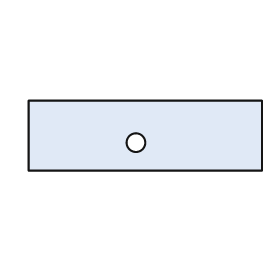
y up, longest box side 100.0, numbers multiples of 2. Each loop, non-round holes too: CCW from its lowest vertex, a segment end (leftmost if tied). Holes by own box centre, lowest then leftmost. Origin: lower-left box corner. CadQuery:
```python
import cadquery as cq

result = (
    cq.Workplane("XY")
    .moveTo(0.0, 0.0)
    .lineTo(100.0, 0.0)
    .lineTo(100.0, 30.0)
    .lineTo(0.0, 30.0)
    .close()
    .moveTo(46.0, 12.0)
    .circle(4.0)
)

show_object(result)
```